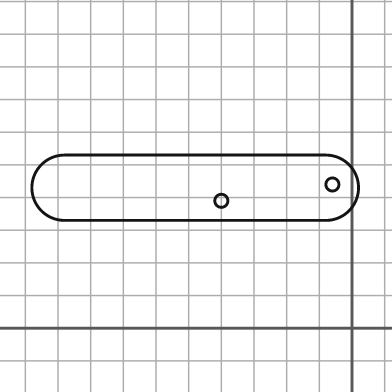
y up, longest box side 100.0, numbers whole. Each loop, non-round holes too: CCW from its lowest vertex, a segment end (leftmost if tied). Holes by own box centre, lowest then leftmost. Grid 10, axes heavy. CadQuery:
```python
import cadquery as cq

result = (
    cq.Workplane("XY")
    .moveTo(-88.0, 33.0)
    .lineTo(-8.0, 33.0)
    .threePointArc((2.0, 43.0), (-8.0, 53.0))
    .lineTo(-88.0, 53.0)
    .threePointArc((-98.0, 43.0), (-88.0, 33.0))
    .close()
    .moveTo(-40.0, 39.0)
    .circle(2.0)
    .moveTo(-6.0, 44.0)
    .circle(2.0)
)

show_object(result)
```